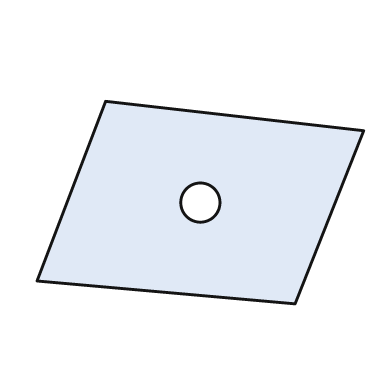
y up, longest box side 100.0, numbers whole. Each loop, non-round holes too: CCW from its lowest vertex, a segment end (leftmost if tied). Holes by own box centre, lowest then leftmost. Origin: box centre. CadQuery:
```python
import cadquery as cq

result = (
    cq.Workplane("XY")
    .moveTo(29.0, -31.0)
    .lineTo(50.0, 22.0)
    .lineTo(-29.0, 31.0)
    .lineTo(-50.0, -24.0)
    .close()
    .moveTo(0.0, 0.0)
    .circle(6.0)
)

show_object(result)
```